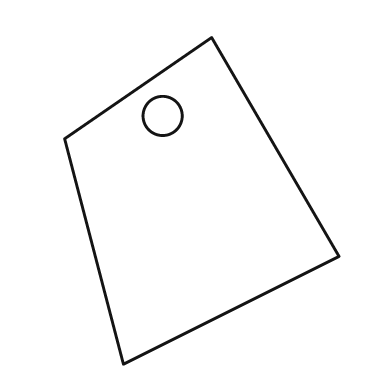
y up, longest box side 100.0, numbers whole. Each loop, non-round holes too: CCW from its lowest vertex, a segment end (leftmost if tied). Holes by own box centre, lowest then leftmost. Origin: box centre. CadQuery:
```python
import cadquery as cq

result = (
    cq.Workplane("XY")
    .moveTo(-24.0, -50.0)
    .lineTo(42.0, -17.0)
    .lineTo(3.0, 50.0)
    .lineTo(-42.0, 19.0)
    .close()
    .moveTo(-12.0, 26.0)
    .circle(6.0)
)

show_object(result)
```